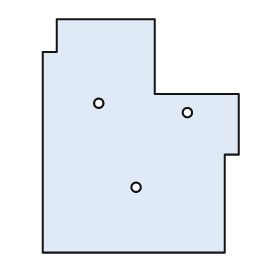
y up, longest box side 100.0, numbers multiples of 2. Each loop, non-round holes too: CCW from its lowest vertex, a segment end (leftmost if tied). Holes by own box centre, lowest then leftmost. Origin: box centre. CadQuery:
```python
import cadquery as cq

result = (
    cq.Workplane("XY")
    .moveTo(-42.0, -50.0)
    .lineTo(36.0, -50.0)
    .lineTo(36.0, -8.0)
    .lineTo(42.0, -8.0)
    .lineTo(42.0, 18.0)
    .lineTo(6.0, 18.0)
    .lineTo(6.0, 50.0)
    .lineTo(-36.0, 50.0)
    .lineTo(-36.0, 36.0)
    .lineTo(-42.0, 36.0)
    .close()
    .moveTo(-2.0, -22.0)
    .circle(2.0)
    .moveTo(20.0, 10.0)
    .circle(2.0)
    .moveTo(-18.0, 14.0)
    .circle(2.0)
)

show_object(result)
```